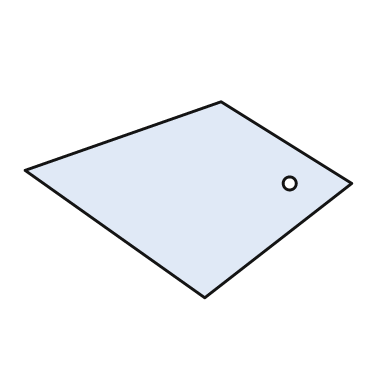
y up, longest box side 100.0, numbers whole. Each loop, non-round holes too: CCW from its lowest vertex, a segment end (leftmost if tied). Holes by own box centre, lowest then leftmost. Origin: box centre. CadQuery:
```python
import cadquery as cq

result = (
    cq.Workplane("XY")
    .moveTo(5.0, -30.0)
    .lineTo(50.0, 5.0)
    .lineTo(10.0, 30.0)
    .lineTo(-50.0, 9.0)
    .close()
    .moveTo(31.0, 5.0)
    .circle(2.0)
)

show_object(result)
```